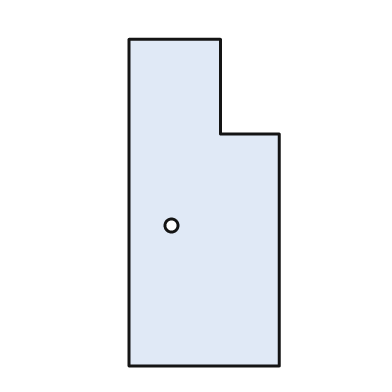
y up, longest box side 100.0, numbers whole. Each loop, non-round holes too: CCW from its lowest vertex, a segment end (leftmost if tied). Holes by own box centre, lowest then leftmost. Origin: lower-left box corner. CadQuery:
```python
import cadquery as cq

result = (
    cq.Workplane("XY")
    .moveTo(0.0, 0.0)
    .lineTo(46.0, 0.0)
    .lineTo(46.0, 71.0)
    .lineTo(28.0, 71.0)
    .lineTo(28.0, 100.0)
    .lineTo(0.0, 100.0)
    .close()
    .moveTo(13.0, 43.0)
    .circle(2.0)
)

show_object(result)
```